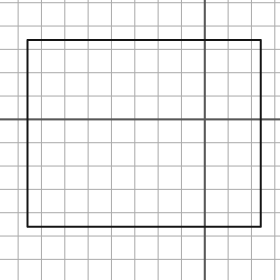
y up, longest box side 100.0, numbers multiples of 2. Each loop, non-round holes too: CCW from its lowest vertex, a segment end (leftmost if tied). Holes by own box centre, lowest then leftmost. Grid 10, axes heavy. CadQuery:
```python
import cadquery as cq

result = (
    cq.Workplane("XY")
    .moveTo(-76.0, -46.0)
    .lineTo(24.0, -46.0)
    .lineTo(24.0, 34.0)
    .lineTo(-76.0, 34.0)
    .close()
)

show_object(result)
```